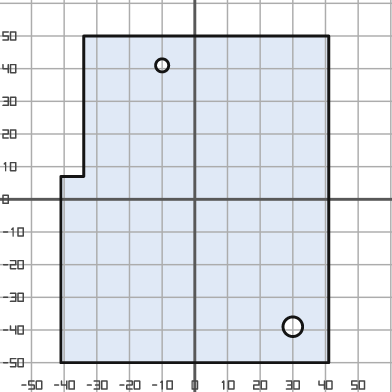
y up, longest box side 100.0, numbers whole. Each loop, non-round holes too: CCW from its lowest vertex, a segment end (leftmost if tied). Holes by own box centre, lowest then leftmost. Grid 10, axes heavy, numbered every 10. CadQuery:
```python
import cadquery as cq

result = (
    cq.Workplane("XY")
    .moveTo(-41.0, -50.0)
    .lineTo(41.0, -50.0)
    .lineTo(41.0, 50.0)
    .lineTo(-34.0, 50.0)
    .lineTo(-34.0, 7.0)
    .lineTo(-41.0, 7.0)
    .close()
    .moveTo(30.0, -39.0)
    .circle(3.0)
    .moveTo(-10.0, 41.0)
    .circle(2.0)
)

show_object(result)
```